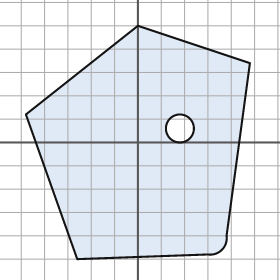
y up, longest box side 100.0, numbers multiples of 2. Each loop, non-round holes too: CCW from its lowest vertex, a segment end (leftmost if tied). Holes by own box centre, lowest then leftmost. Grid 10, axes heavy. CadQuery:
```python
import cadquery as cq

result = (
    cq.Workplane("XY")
    .moveTo(-26.0, -50.0)
    .lineTo(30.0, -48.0)
    .threePointArc((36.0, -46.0), (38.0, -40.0))
    .lineTo(48.0, 34.0)
    .lineTo(0.0, 50.0)
    .lineTo(-48.0, 12.0)
    .close()
    .moveTo(18.0, 6.0)
    .circle(6.0)
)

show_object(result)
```